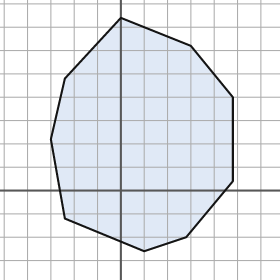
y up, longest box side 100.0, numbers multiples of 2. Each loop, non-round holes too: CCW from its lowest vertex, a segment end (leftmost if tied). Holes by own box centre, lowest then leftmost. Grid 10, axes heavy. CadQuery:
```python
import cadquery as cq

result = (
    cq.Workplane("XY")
    .moveTo(10.0, -26.0)
    .lineTo(28.0, -20.0)
    .lineTo(48.0, 4.0)
    .lineTo(48.0, 40.0)
    .lineTo(30.0, 62.0)
    .lineTo(0.0, 74.0)
    .lineTo(-24.0, 48.0)
    .lineTo(-30.0, 22.0)
    .lineTo(-24.0, -12.0)
    .close()
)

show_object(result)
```